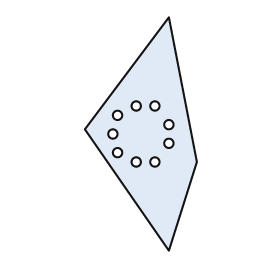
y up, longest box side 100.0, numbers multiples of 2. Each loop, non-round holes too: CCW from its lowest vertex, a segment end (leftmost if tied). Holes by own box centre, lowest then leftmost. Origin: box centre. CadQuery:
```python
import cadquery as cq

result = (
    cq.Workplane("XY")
    .moveTo(12.0, -50.0)
    .lineTo(24.0, -12.0)
    .lineTo(12.0, 50.0)
    .lineTo(-24.0, 2.0)
    .close()
    .moveTo(-2.0, -12.0)
    .circle(2.0)
    .moveTo(6.0, -12.0)
    .circle(2.0)
    .moveTo(-10.0, -8.0)
    .circle(2.0)
    .moveTo(12.0, -4.0)
    .circle(2.0)
    .moveTo(-12.0, 0.0)
    .circle(2.0)
    .moveTo(12.0, 4.0)
    .circle(2.0)
    .moveTo(-10.0, 8.0)
    .circle(2.0)
    .moveTo(-2.0, 12.0)
    .circle(2.0)
    .moveTo(6.0, 12.0)
    .circle(2.0)
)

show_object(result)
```